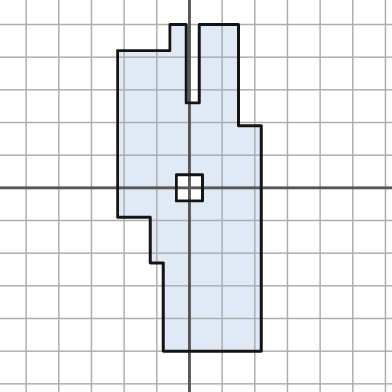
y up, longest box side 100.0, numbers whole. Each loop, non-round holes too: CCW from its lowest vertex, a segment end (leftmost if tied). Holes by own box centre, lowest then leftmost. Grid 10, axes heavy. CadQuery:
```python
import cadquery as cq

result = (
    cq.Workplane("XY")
    .moveTo(-8.0, -50.0)
    .lineTo(22.0, -50.0)
    .lineTo(22.0, 19.0)
    .lineTo(15.0, 19.0)
    .lineTo(15.0, 50.0)
    .lineTo(3.0, 50.0)
    .lineTo(3.0, 26.0)
    .lineTo(-1.0, 26.0)
    .lineTo(-1.0, 50.0)
    .lineTo(-6.0, 50.0)
    .lineTo(-6.0, 42.0)
    .lineTo(-22.0, 42.0)
    .lineTo(-22.0, -9.0)
    .lineTo(-12.0, -9.0)
    .lineTo(-12.0, -23.0)
    .lineTo(-8.0, -23.0)
    .close()
    .moveTo(-4.0, -4.0)
    .lineTo(4.0, -4.0)
    .lineTo(4.0, 4.0)
    .lineTo(-4.0, 4.0)
    .close()
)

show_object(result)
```